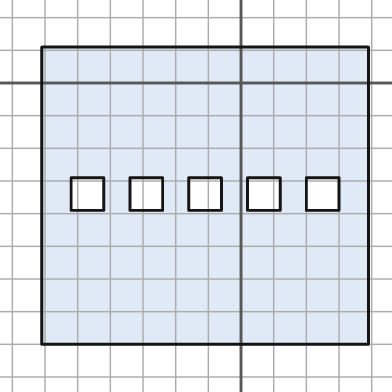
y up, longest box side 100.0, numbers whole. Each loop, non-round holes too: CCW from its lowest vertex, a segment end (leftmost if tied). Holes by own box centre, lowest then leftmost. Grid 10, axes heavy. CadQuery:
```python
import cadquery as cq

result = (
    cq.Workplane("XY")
    .moveTo(-61.0, -80.0)
    .lineTo(39.0, -80.0)
    .lineTo(39.0, 11.0)
    .lineTo(-61.0, 11.0)
    .close()
    .moveTo(-52.0, -39.0)
    .lineTo(-42.0, -39.0)
    .lineTo(-42.0, -29.0)
    .lineTo(-52.0, -29.0)
    .close()
    .moveTo(-34.0, -39.0)
    .lineTo(-24.0, -39.0)
    .lineTo(-24.0, -29.0)
    .lineTo(-34.0, -29.0)
    .close()
    .moveTo(-16.0, -39.0)
    .lineTo(-6.0, -39.0)
    .lineTo(-6.0, -29.0)
    .lineTo(-16.0, -29.0)
    .close()
    .moveTo(2.0, -39.0)
    .lineTo(12.0, -39.0)
    .lineTo(12.0, -29.0)
    .lineTo(2.0, -29.0)
    .close()
    .moveTo(20.0, -39.0)
    .lineTo(30.0, -39.0)
    .lineTo(30.0, -29.0)
    .lineTo(20.0, -29.0)
    .close()
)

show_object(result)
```